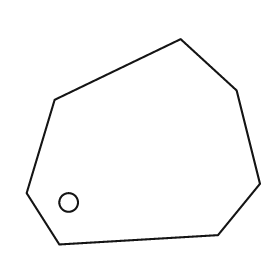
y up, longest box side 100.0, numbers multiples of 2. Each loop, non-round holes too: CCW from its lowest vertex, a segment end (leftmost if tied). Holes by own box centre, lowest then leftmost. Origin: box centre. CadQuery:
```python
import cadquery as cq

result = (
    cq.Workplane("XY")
    .moveTo(-36.0, -44.0)
    .lineTo(32.0, -40.0)
    .lineTo(50.0, -18.0)
    .lineTo(40.0, 22.0)
    .lineTo(16.0, 44.0)
    .lineTo(-38.0, 18.0)
    .lineTo(-50.0, -22.0)
    .close()
    .moveTo(-32.0, -26.0)
    .circle(4.0)
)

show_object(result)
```